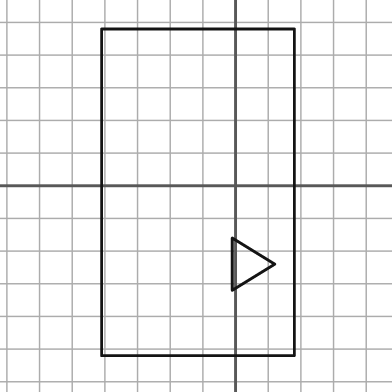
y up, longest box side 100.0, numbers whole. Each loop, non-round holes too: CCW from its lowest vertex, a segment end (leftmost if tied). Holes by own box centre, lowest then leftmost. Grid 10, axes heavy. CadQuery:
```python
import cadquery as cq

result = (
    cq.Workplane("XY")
    .moveTo(-41.0, -52.0)
    .lineTo(18.0, -52.0)
    .lineTo(18.0, 48.0)
    .lineTo(-41.0, 48.0)
    .close()
    .moveTo(-1.0, -32.0)
    .lineTo(12.0, -24.0)
    .lineTo(-1.0, -16.0)
    .close()
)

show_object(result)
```